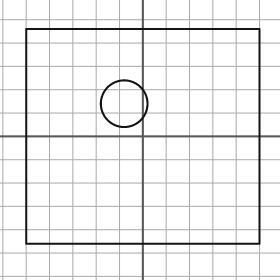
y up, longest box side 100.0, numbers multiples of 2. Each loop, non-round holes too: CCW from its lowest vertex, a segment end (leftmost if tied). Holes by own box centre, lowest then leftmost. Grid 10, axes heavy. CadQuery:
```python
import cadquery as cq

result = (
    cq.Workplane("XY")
    .moveTo(-50.0, -46.0)
    .lineTo(50.0, -46.0)
    .lineTo(50.0, 46.0)
    .lineTo(-50.0, 46.0)
    .close()
    .moveTo(-8.0, 14.0)
    .circle(10.0)
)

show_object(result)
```